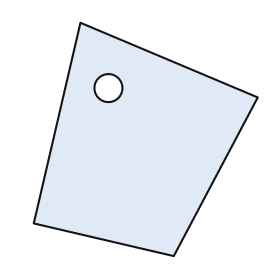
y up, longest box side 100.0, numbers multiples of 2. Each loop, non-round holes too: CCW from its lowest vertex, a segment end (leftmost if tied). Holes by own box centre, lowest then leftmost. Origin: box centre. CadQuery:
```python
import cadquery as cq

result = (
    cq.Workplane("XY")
    .moveTo(12.0, -50.0)
    .lineTo(48.0, 18.0)
    .lineTo(-28.0, 50.0)
    .lineTo(-48.0, -36.0)
    .close()
    .moveTo(-16.0, 22.0)
    .circle(6.0)
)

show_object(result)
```